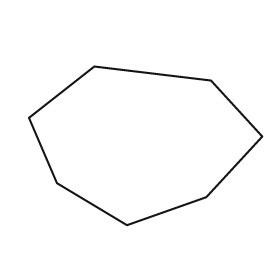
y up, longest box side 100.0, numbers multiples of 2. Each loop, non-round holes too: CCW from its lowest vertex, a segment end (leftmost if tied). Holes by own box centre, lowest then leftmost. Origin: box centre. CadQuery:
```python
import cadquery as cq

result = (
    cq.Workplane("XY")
    .moveTo(-8.0, -34.0)
    .lineTo(26.0, -22.0)
    .lineTo(50.0, 4.0)
    .lineTo(28.0, 28.0)
    .lineTo(-22.0, 34.0)
    .lineTo(-50.0, 12.0)
    .lineTo(-38.0, -16.0)
    .close()
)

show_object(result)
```